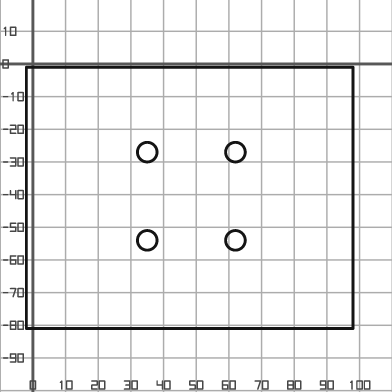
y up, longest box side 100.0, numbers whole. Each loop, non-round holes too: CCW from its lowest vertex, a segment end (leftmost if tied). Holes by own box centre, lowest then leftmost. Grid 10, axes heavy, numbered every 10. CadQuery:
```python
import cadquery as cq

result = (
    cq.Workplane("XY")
    .moveTo(-2.0, -81.0)
    .lineTo(98.0, -81.0)
    .lineTo(98.0, -1.0)
    .lineTo(-2.0, -1.0)
    .close()
    .moveTo(35.0, -54.0)
    .circle(3.0)
    .moveTo(62.0, -54.0)
    .circle(3.0)
    .moveTo(35.0, -27.0)
    .circle(3.0)
    .moveTo(62.0, -27.0)
    .circle(3.0)
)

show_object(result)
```